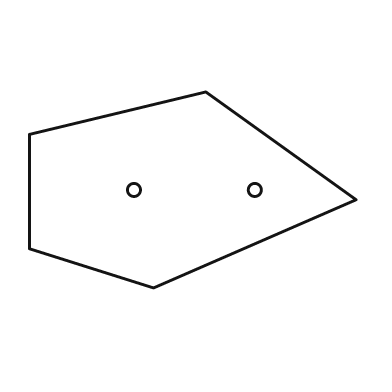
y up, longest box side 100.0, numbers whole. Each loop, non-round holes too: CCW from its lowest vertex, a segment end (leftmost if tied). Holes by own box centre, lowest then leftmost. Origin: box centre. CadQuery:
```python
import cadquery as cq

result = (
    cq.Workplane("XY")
    .moveTo(-12.0, -30.0)
    .lineTo(50.0, -3.0)
    .lineTo(4.0, 30.0)
    .lineTo(-50.0, 17.0)
    .lineTo(-50.0, -18.0)
    .close()
    .moveTo(-18.0, 0.0)
    .circle(2.0)
    .moveTo(19.0, 0.0)
    .circle(2.0)
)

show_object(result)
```